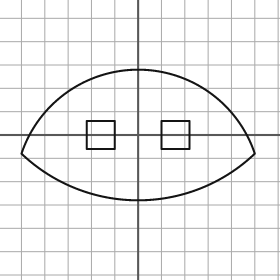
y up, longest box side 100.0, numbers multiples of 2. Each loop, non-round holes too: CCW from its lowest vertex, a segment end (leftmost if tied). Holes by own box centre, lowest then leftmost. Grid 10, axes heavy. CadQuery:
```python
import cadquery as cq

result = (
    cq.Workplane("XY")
    .moveTo(-50.0, -8.0)
    .threePointArc((0.0, -28.0), (50.0, -8.0))
    .threePointArc((0.0, 28.0), (-50.0, -8.0))
    .close()
    .moveTo(-22.0, -6.0)
    .lineTo(-10.0, -6.0)
    .lineTo(-10.0, 6.0)
    .lineTo(-22.0, 6.0)
    .close()
    .moveTo(10.0, -6.0)
    .lineTo(22.0, -6.0)
    .lineTo(22.0, 6.0)
    .lineTo(10.0, 6.0)
    .close()
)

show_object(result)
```